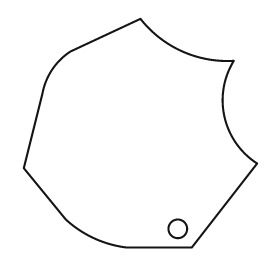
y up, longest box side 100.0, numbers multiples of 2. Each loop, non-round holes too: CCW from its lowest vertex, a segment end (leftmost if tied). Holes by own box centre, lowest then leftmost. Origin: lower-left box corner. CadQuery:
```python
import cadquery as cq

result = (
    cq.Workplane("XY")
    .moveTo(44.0, 0.0)
    .lineTo(72.0, 0.0)
    .lineTo(100.0, 36.0)
    .threePointArc((86.0, 56.0), (90.0, 80.0))
    .threePointArc((68.0, 84.0), (50.0, 98.0))
    .lineTo(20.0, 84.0)
    .threePointArc((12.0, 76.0), (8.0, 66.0))
    .lineTo(0.0, 34.0)
    .lineTo(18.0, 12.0)
    .threePointArc((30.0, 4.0), (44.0, 0.0))
    .close()
    .moveTo(66.0, 8.0)
    .circle(4.0)
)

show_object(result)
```